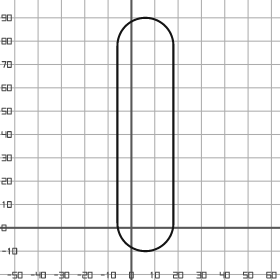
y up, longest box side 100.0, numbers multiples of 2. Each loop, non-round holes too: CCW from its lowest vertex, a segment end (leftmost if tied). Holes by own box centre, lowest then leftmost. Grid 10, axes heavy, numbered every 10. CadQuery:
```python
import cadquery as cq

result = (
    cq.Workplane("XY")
    .moveTo(-6.0, 2.0)
    .threePointArc((6.0, -10.0), (18.0, 2.0))
    .lineTo(18.0, 78.0)
    .threePointArc((6.0, 90.0), (-6.0, 78.0))
    .close()
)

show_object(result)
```